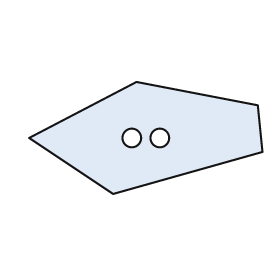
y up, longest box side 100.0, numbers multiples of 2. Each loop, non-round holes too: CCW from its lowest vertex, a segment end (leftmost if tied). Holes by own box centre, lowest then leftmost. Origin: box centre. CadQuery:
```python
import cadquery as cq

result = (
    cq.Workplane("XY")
    .moveTo(-14.0, -24.0)
    .lineTo(50.0, -6.0)
    .lineTo(48.0, 14.0)
    .lineTo(-4.0, 24.0)
    .lineTo(-50.0, 0.0)
    .close()
    .moveTo(-6.0, 0.0)
    .circle(4.0)
    .moveTo(6.0, 0.0)
    .circle(4.0)
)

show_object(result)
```